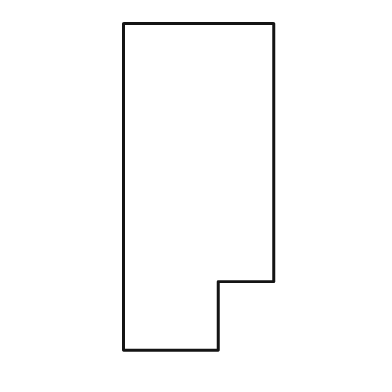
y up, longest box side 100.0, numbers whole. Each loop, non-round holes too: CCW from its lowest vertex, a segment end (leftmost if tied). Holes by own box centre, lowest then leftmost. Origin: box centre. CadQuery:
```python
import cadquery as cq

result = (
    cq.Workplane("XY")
    .moveTo(-23.0, -50.0)
    .lineTo(6.0, -50.0)
    .lineTo(6.0, -29.0)
    .lineTo(23.0, -29.0)
    .lineTo(23.0, 50.0)
    .lineTo(-23.0, 50.0)
    .close()
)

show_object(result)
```